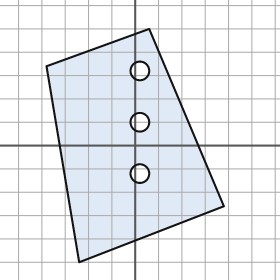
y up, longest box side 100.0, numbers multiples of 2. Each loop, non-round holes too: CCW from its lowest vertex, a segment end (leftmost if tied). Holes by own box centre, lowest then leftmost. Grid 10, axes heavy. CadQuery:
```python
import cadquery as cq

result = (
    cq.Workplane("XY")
    .moveTo(-24.0, -50.0)
    .lineTo(38.0, -26.0)
    .lineTo(6.0, 50.0)
    .lineTo(-38.0, 34.0)
    .close()
    .moveTo(2.0, -12.0)
    .circle(4.0)
    .moveTo(2.0, 10.0)
    .circle(4.0)
    .moveTo(2.0, 32.0)
    .circle(4.0)
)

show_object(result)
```